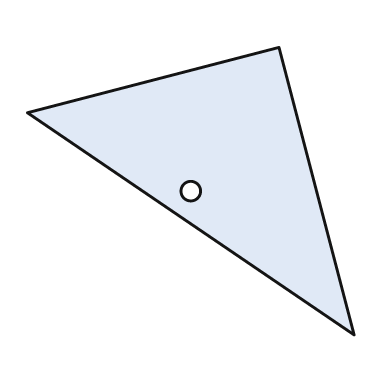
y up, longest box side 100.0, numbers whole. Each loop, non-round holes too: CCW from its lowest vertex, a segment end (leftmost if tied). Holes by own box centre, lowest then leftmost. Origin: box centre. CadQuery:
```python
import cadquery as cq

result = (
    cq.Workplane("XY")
    .moveTo(50.0, -44.0)
    .lineTo(27.0, 44.0)
    .lineTo(-50.0, 24.0)
    .close()
    .moveTo(0.0, 0.0)
    .circle(3.0)
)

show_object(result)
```